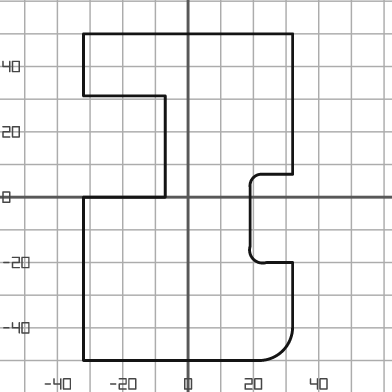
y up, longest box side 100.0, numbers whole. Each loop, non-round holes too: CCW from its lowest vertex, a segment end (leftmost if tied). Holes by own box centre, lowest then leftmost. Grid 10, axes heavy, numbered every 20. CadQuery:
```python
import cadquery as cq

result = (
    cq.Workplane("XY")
    .moveTo(-32.0, -50.0)
    .lineTo(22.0, -50.0)
    .threePointArc((29.0, -47.0), (32.0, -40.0))
    .lineTo(32.0, -20.0)
    .lineTo(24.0, -20.0)
    .threePointArc((20.0, -19.0), (19.0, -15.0))
    .lineTo(19.0, 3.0)
    .threePointArc((20.0, 6.0), (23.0, 7.0))
    .lineTo(32.0, 7.0)
    .lineTo(32.0, 50.0)
    .lineTo(-32.0, 50.0)
    .lineTo(-32.0, 31.0)
    .lineTo(-7.0, 31.0)
    .lineTo(-7.0, 0.0)
    .lineTo(-32.0, 0.0)
    .close()
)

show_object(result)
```